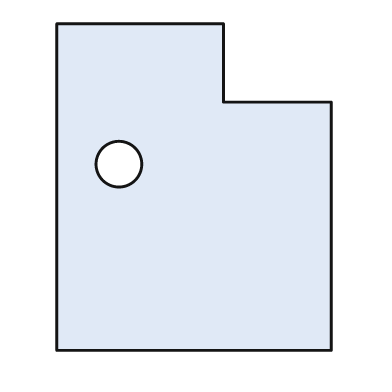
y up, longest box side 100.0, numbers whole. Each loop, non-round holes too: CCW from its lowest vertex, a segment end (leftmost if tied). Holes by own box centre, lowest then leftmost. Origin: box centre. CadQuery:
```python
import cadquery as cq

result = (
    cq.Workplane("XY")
    .moveTo(-42.0, -50.0)
    .lineTo(42.0, -50.0)
    .lineTo(42.0, 26.0)
    .lineTo(9.0, 26.0)
    .lineTo(9.0, 50.0)
    .lineTo(-42.0, 50.0)
    .close()
    .moveTo(-23.0, 7.0)
    .circle(7.0)
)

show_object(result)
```